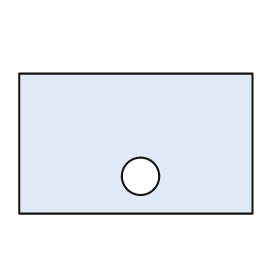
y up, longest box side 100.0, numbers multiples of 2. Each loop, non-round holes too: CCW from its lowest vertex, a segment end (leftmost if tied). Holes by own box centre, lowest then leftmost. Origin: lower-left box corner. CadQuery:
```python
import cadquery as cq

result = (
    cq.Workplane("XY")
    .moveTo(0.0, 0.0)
    .lineTo(100.0, 0.0)
    .lineTo(100.0, 60.0)
    .lineTo(0.0, 60.0)
    .close()
    .moveTo(52.0, 16.0)
    .circle(8.0)
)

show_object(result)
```